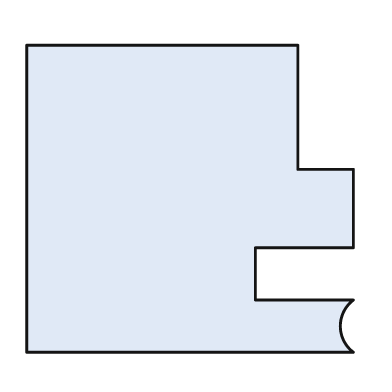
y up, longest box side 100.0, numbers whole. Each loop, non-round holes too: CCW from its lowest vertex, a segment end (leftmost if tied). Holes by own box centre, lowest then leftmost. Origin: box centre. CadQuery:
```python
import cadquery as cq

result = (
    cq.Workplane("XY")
    .moveTo(-50.0, -47.0)
    .lineTo(50.0, -47.0)
    .threePointArc((46.0, -39.0), (50.0, -31.0))
    .lineTo(20.0, -31.0)
    .lineTo(20.0, -15.0)
    .lineTo(50.0, -15.0)
    .lineTo(50.0, 9.0)
    .lineTo(33.0, 9.0)
    .lineTo(33.0, 47.0)
    .lineTo(-50.0, 47.0)
    .close()
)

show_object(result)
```